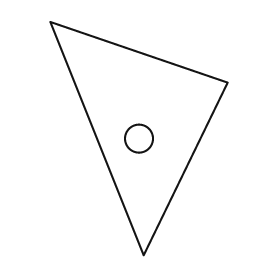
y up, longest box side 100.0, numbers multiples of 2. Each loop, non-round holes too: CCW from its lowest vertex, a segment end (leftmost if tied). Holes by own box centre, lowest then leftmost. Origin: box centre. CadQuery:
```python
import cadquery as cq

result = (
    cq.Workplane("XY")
    .moveTo(2.0, -50.0)
    .lineTo(38.0, 24.0)
    .lineTo(-38.0, 50.0)
    .close()
    .moveTo(0.0, 0.0)
    .circle(6.0)
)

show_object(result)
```